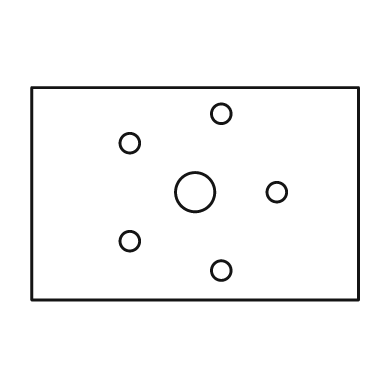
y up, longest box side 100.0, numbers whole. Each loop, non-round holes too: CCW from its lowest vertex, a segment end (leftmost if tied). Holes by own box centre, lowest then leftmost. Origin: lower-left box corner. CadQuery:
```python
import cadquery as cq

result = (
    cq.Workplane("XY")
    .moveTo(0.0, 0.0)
    .lineTo(100.0, 0.0)
    .lineTo(100.0, 65.0)
    .lineTo(0.0, 65.0)
    .close()
    .moveTo(58.0, 9.0)
    .circle(3.0)
    .moveTo(30.0, 18.0)
    .circle(3.0)
    .moveTo(50.0, 33.0)
    .circle(6.0)
    .moveTo(75.0, 33.0)
    .circle(3.0)
    .moveTo(30.0, 48.0)
    .circle(3.0)
    .moveTo(58.0, 57.0)
    .circle(3.0)
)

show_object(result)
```